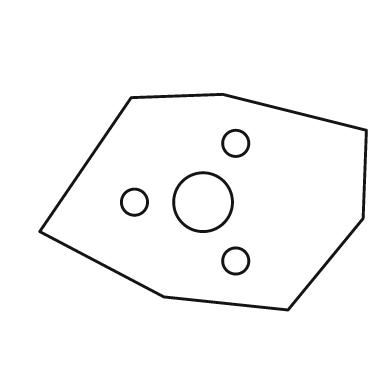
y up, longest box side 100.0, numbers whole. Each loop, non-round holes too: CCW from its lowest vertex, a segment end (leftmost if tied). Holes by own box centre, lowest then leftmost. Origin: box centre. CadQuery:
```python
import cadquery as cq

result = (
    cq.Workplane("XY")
    .moveTo(26.0, -33.0)
    .lineTo(49.0, -5.0)
    .lineTo(50.0, 22.0)
    .lineTo(6.0, 33.0)
    .lineTo(-22.0, 32.0)
    .lineTo(-50.0, -9.0)
    .lineTo(-12.0, -29.0)
    .close()
    .moveTo(10.0, -18.0)
    .circle(4.0)
    .moveTo(-21.0, 0.0)
    .circle(4.0)
    .moveTo(0.0, 0.0)
    .circle(9.0)
    .moveTo(10.0, 18.0)
    .circle(4.0)
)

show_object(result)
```